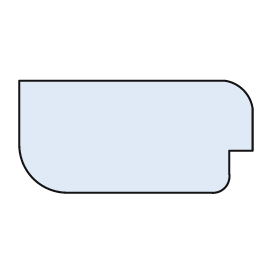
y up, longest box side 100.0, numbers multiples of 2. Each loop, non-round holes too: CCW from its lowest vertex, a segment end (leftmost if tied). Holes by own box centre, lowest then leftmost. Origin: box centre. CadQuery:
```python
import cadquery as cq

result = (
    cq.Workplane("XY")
    .moveTo(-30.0, -24.0)
    .lineTo(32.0, -24.0)
    .threePointArc((38.0, -22.0), (40.0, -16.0))
    .lineTo(40.0, -6.0)
    .lineTo(50.0, -6.0)
    .lineTo(50.0, 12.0)
    .threePointArc((46.0, 20.0), (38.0, 24.0))
    .lineTo(-50.0, 24.0)
    .lineTo(-50.0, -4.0)
    .threePointArc((-44.0, -18.0), (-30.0, -24.0))
    .close()
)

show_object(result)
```